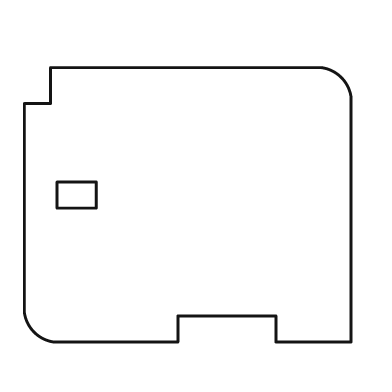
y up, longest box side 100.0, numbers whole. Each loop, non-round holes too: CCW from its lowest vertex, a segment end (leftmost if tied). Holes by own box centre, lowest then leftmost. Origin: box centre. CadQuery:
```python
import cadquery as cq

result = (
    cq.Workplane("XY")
    .moveTo(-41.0, -42.0)
    .lineTo(-3.0, -42.0)
    .lineTo(-3.0, -34.0)
    .lineTo(27.0, -34.0)
    .lineTo(27.0, -42.0)
    .lineTo(50.0, -42.0)
    .lineTo(50.0, 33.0)
    .threePointArc((47.0, 39.0), (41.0, 42.0))
    .lineTo(-42.0, 42.0)
    .lineTo(-42.0, 31.0)
    .lineTo(-50.0, 31.0)
    .lineTo(-50.0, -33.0)
    .threePointArc((-47.0, -39.0), (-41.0, -42.0))
    .close()
    .moveTo(-40.0, -1.0)
    .lineTo(-28.0, -1.0)
    .lineTo(-28.0, 7.0)
    .lineTo(-40.0, 7.0)
    .close()
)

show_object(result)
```